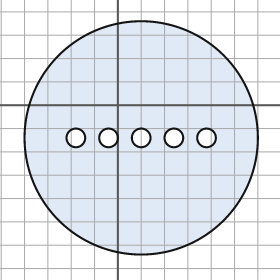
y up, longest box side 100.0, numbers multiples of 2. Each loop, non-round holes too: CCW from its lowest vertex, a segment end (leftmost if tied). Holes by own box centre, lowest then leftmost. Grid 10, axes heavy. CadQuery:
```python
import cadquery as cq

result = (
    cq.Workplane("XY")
    .moveTo(10.0, -14.0)
    .circle(50.0)
    .moveTo(-18.0, -14.0)
    .circle(4.0)
    .moveTo(-4.0, -14.0)
    .circle(4.0)
    .moveTo(10.0, -14.0)
    .circle(4.0)
    .moveTo(24.0, -14.0)
    .circle(4.0)
    .moveTo(38.0, -14.0)
    .circle(4.0)
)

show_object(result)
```